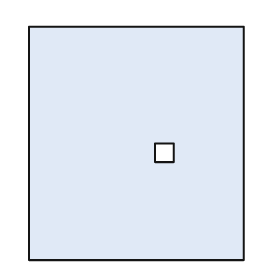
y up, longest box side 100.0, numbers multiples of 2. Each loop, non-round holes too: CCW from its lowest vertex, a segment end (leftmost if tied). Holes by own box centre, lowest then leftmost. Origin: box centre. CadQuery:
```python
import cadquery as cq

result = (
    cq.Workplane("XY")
    .moveTo(-46.0, -50.0)
    .lineTo(46.0, -50.0)
    .lineTo(46.0, 50.0)
    .lineTo(-46.0, 50.0)
    .close()
    .moveTo(8.0, -8.0)
    .lineTo(16.0, -8.0)
    .lineTo(16.0, 0.0)
    .lineTo(8.0, 0.0)
    .close()
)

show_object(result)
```